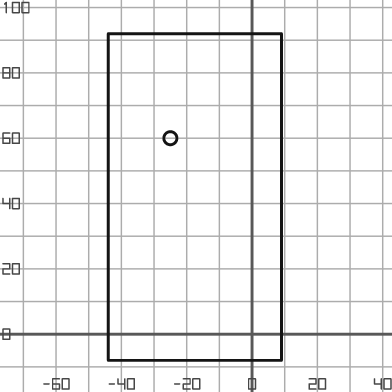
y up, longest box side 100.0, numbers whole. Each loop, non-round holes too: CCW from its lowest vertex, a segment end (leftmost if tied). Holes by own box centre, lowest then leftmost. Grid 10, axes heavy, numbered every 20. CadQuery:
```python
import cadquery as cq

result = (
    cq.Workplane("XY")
    .moveTo(-44.0, -8.0)
    .lineTo(9.0, -8.0)
    .lineTo(9.0, 92.0)
    .lineTo(-44.0, 92.0)
    .close()
    .moveTo(-25.0, 60.0)
    .circle(2.0)
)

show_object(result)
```